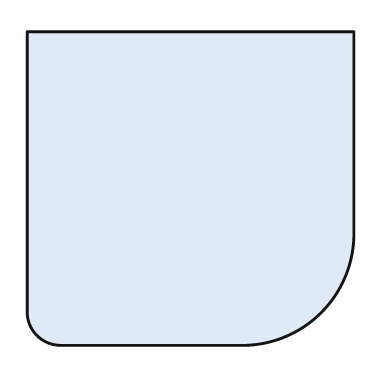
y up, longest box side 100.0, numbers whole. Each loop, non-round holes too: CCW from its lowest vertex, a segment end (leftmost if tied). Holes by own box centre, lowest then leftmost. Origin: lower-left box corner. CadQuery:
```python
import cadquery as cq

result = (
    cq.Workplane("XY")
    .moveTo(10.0, 0.0)
    .lineTo(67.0, 0.0)
    .threePointArc((90.0, 10.0), (100.0, 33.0))
    .lineTo(100.0, 96.0)
    .lineTo(0.0, 96.0)
    .lineTo(0.0, 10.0)
    .threePointArc((3.0, 3.0), (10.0, 0.0))
    .close()
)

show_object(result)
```